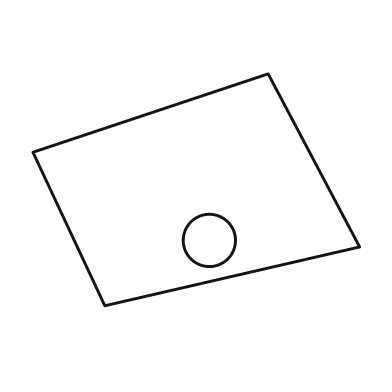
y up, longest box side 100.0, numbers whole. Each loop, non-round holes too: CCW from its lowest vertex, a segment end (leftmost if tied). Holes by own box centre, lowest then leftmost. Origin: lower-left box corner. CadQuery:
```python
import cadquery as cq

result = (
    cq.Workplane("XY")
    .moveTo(22.0, 0.0)
    .lineTo(100.0, 18.0)
    .lineTo(72.0, 71.0)
    .lineTo(0.0, 47.0)
    .close()
    .moveTo(54.0, 20.0)
    .circle(8.0)
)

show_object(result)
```